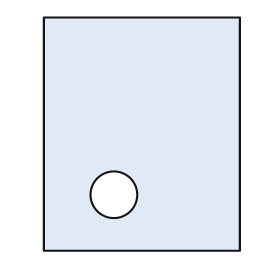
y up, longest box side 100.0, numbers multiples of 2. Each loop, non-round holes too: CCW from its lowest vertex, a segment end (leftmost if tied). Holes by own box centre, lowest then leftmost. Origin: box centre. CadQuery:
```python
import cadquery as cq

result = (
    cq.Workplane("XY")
    .moveTo(-42.0, -50.0)
    .lineTo(42.0, -50.0)
    .lineTo(42.0, 50.0)
    .lineTo(-42.0, 50.0)
    .close()
    .moveTo(-12.0, -26.0)
    .circle(10.0)
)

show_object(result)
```